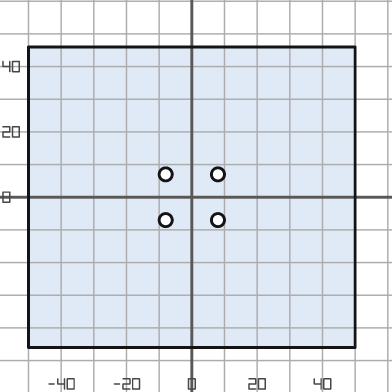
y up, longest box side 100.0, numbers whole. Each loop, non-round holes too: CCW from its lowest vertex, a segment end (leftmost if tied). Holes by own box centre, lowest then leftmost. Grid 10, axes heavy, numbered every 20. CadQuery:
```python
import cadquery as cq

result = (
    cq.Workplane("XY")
    .moveTo(-50.0, -46.0)
    .lineTo(50.0, -46.0)
    .lineTo(50.0, 46.0)
    .lineTo(-50.0, 46.0)
    .close()
    .moveTo(-8.0, -7.0)
    .circle(2.0)
    .moveTo(8.0, -7.0)
    .circle(2.0)
    .moveTo(-8.0, 7.0)
    .circle(2.0)
    .moveTo(8.0, 7.0)
    .circle(2.0)
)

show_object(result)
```